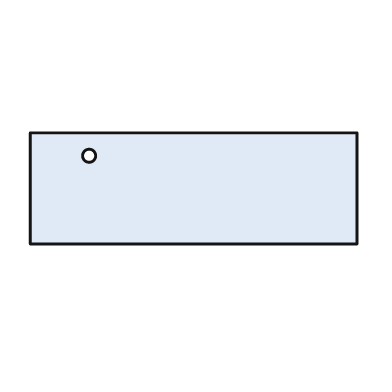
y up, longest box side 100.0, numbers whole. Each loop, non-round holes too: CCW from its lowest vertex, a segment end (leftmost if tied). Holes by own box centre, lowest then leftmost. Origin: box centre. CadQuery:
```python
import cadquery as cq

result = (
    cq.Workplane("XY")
    .moveTo(-50.0, -17.0)
    .lineTo(50.0, -17.0)
    .lineTo(50.0, 17.0)
    .lineTo(-50.0, 17.0)
    .close()
    .moveTo(-32.0, 10.0)
    .circle(2.0)
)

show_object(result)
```